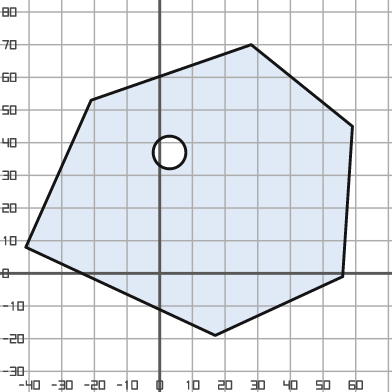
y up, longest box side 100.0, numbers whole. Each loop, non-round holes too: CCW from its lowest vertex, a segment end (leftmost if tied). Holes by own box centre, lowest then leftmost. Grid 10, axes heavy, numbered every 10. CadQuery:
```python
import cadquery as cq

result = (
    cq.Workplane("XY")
    .moveTo(17.0, -19.0)
    .lineTo(56.0, -1.0)
    .lineTo(59.0, 45.0)
    .lineTo(28.0, 70.0)
    .lineTo(-21.0, 53.0)
    .lineTo(-41.0, 8.0)
    .close()
    .moveTo(3.0, 37.0)
    .circle(5.0)
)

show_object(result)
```